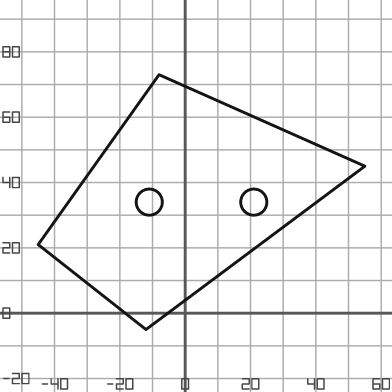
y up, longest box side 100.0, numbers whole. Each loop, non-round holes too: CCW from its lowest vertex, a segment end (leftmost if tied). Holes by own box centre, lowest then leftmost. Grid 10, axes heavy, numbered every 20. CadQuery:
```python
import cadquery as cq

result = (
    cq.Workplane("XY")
    .moveTo(-12.0, -5.0)
    .lineTo(55.0, 45.0)
    .lineTo(-8.0, 73.0)
    .lineTo(-45.0, 21.0)
    .close()
    .moveTo(-11.0, 34.0)
    .circle(4.0)
    .moveTo(21.0, 34.0)
    .circle(4.0)
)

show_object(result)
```